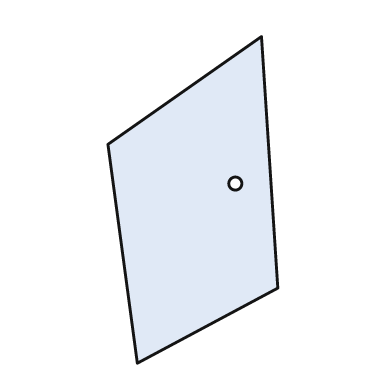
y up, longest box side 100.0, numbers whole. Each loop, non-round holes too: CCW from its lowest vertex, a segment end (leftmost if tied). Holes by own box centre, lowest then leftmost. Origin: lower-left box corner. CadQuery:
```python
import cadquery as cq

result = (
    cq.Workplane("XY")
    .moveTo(9.0, 0.0)
    .lineTo(52.0, 23.0)
    .lineTo(47.0, 100.0)
    .lineTo(0.0, 67.0)
    .close()
    .moveTo(39.0, 55.0)
    .circle(2.0)
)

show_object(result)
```